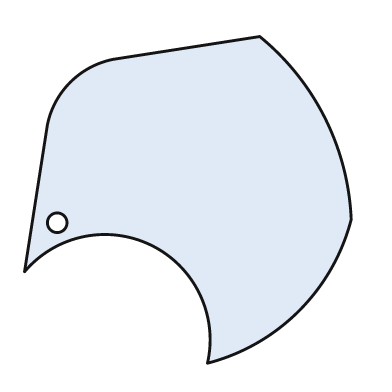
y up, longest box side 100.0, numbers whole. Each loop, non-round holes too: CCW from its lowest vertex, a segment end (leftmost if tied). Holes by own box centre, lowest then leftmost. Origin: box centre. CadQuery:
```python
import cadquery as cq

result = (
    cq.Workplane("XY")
    .moveTo(6.0, -50.0)
    .threePointArc((34.0, -34.0), (50.0, -6.0))
    .threePointArc((42.0, 25.0), (22.0, 50.0))
    .lineTo(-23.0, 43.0)
    .threePointArc((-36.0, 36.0), (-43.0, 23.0))
    .lineTo(-50.0, -22.0)
    .threePointArc((-11.0, -14.0), (6.0, -50.0))
    .close()
    .moveTo(-40.0, -7.0)
    .circle(3.0)
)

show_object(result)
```